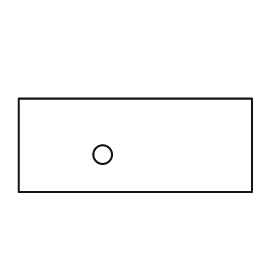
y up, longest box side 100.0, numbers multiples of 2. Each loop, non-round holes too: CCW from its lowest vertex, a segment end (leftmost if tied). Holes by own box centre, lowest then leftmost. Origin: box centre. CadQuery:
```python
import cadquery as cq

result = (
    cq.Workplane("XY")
    .moveTo(-50.0, -20.0)
    .lineTo(50.0, -20.0)
    .lineTo(50.0, 20.0)
    .lineTo(-50.0, 20.0)
    .close()
    .moveTo(-14.0, -4.0)
    .circle(4.0)
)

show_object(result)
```